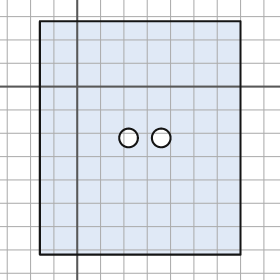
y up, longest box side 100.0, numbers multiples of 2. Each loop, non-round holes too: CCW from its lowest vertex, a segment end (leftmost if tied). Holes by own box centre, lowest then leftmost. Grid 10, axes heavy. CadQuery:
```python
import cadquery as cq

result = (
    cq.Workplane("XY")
    .moveTo(-16.0, -72.0)
    .lineTo(70.0, -72.0)
    .lineTo(70.0, 28.0)
    .lineTo(-16.0, 28.0)
    .close()
    .moveTo(22.0, -22.0)
    .circle(4.0)
    .moveTo(36.0, -22.0)
    .circle(4.0)
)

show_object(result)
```